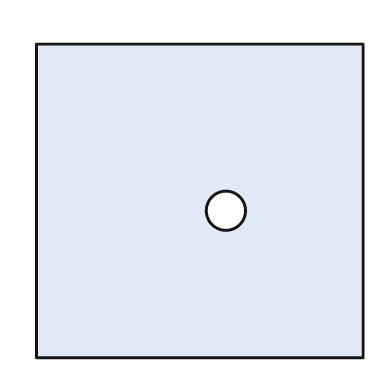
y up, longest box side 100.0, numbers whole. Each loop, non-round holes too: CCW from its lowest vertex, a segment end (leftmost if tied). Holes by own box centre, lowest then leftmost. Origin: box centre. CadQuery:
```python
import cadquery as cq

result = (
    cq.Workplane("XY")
    .moveTo(-50.0, -48.0)
    .lineTo(50.0, -48.0)
    .lineTo(50.0, 48.0)
    .lineTo(-50.0, 48.0)
    .close()
    .moveTo(8.0, -3.0)
    .circle(6.0)
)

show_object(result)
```